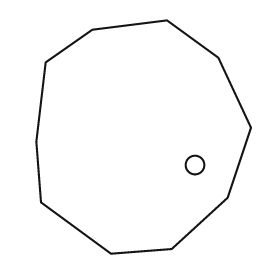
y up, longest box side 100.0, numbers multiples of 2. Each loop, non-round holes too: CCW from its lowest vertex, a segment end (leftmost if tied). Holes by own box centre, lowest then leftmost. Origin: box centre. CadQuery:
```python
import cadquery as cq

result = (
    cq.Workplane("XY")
    .moveTo(-14.0, -50.0)
    .lineTo(12.0, -48.0)
    .lineTo(36.0, -26.0)
    .lineTo(46.0, 4.0)
    .lineTo(32.0, 34.0)
    .lineTo(10.0, 50.0)
    .lineTo(-22.0, 46.0)
    .lineTo(-42.0, 32.0)
    .lineTo(-46.0, -2.0)
    .lineTo(-44.0, -28.0)
    .close()
    .moveTo(22.0, -12.0)
    .circle(4.0)
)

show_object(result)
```